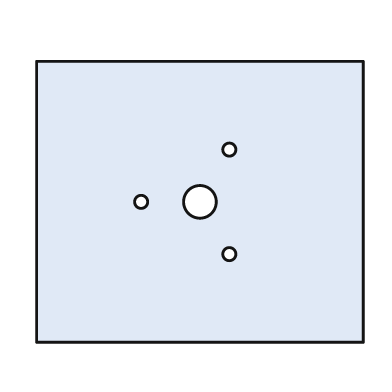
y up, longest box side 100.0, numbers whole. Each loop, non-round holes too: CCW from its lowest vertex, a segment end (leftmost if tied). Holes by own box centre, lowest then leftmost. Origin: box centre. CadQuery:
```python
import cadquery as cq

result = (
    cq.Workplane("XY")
    .moveTo(-50.0, -43.0)
    .lineTo(50.0, -43.0)
    .lineTo(50.0, 43.0)
    .lineTo(-50.0, 43.0)
    .close()
    .moveTo(9.0, -16.0)
    .circle(2.0)
    .moveTo(-18.0, 0.0)
    .circle(2.0)
    .moveTo(0.0, 0.0)
    .circle(5.0)
    .moveTo(9.0, 16.0)
    .circle(2.0)
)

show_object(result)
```